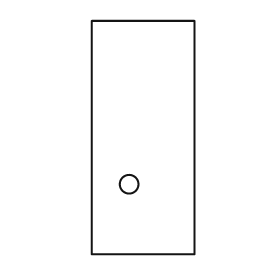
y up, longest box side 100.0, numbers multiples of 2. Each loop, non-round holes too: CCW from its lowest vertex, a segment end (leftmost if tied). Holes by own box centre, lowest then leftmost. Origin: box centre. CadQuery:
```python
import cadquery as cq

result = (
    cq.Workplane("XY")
    .moveTo(-22.0, -50.0)
    .lineTo(22.0, -50.0)
    .lineTo(22.0, 50.0)
    .lineTo(-22.0, 50.0)
    .close()
    .moveTo(-6.0, -20.0)
    .circle(4.0)
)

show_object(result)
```